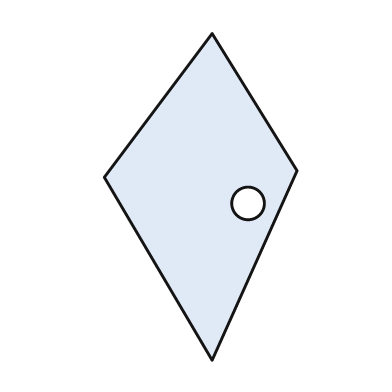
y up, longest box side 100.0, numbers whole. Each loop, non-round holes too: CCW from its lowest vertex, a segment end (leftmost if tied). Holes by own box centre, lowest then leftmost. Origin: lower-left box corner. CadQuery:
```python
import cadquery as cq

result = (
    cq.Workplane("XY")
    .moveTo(33.0, 0.0)
    .lineTo(59.0, 58.0)
    .lineTo(33.0, 100.0)
    .lineTo(0.0, 56.0)
    .close()
    .moveTo(44.0, 48.0)
    .circle(5.0)
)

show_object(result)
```